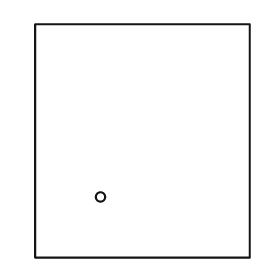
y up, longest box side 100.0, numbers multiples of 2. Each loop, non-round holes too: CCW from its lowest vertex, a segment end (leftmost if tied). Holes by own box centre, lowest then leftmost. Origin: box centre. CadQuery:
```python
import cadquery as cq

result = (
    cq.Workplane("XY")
    .moveTo(-46.0, -50.0)
    .lineTo(46.0, -50.0)
    .lineTo(46.0, 50.0)
    .lineTo(-46.0, 50.0)
    .close()
    .moveTo(-18.0, -24.0)
    .circle(2.0)
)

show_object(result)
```